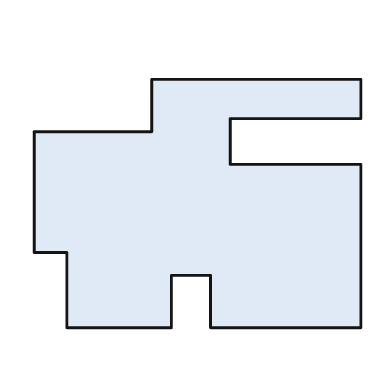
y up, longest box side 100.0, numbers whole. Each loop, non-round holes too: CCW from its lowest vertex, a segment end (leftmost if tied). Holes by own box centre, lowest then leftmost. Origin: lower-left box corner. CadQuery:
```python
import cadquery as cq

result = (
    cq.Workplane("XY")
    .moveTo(10.0, 0.0)
    .lineTo(42.0, 0.0)
    .lineTo(42.0, 16.0)
    .lineTo(54.0, 16.0)
    .lineTo(54.0, 0.0)
    .lineTo(100.0, 0.0)
    .lineTo(100.0, 50.0)
    .lineTo(60.0, 50.0)
    .lineTo(60.0, 64.0)
    .lineTo(100.0, 64.0)
    .lineTo(100.0, 76.0)
    .lineTo(36.0, 76.0)
    .lineTo(36.0, 60.0)
    .lineTo(0.0, 60.0)
    .lineTo(0.0, 23.0)
    .lineTo(10.0, 23.0)
    .close()
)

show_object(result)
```